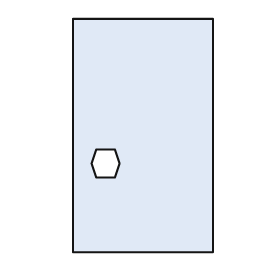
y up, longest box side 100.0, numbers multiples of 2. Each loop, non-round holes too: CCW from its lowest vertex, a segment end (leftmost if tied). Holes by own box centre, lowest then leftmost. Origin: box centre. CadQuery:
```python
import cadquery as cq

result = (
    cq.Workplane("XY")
    .moveTo(-30.0, -50.0)
    .lineTo(30.0, -50.0)
    .lineTo(30.0, 50.0)
    .lineTo(-30.0, 50.0)
    .close()
    .moveTo(-20.0, -18.0)
    .lineTo(-12.0, -18.0)
    .lineTo(-10.0, -12.0)
    .lineTo(-12.0, -6.0)
    .lineTo(-20.0, -6.0)
    .lineTo(-22.0, -12.0)
    .close()
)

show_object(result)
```